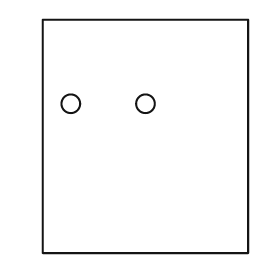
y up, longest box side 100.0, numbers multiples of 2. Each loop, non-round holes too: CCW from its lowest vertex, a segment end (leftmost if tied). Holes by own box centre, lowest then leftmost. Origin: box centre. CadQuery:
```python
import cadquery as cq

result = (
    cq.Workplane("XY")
    .moveTo(-44.0, -50.0)
    .lineTo(44.0, -50.0)
    .lineTo(44.0, 50.0)
    .lineTo(-44.0, 50.0)
    .close()
    .moveTo(-32.0, 14.0)
    .circle(4.0)
    .moveTo(0.0, 14.0)
    .circle(4.0)
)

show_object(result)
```